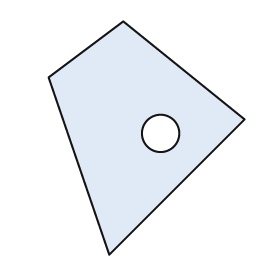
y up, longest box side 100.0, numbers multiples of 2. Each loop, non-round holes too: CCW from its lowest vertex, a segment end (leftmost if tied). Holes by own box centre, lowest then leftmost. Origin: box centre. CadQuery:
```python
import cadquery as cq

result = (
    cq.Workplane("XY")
    .moveTo(-16.0, -50.0)
    .lineTo(42.0, 8.0)
    .lineTo(-10.0, 50.0)
    .lineTo(-42.0, 26.0)
    .close()
    .moveTo(6.0, 2.0)
    .circle(8.0)
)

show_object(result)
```